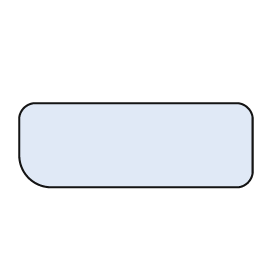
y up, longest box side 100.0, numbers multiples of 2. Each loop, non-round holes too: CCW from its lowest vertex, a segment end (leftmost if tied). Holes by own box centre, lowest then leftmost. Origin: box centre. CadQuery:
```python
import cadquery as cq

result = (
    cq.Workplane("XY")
    .moveTo(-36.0, -18.0)
    .lineTo(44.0, -18.0)
    .threePointArc((48.0, -16.0), (50.0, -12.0))
    .lineTo(50.0, 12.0)
    .threePointArc((48.0, 16.0), (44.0, 18.0))
    .lineTo(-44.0, 18.0)
    .threePointArc((-48.0, 16.0), (-50.0, 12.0))
    .lineTo(-50.0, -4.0)
    .threePointArc((-46.0, -14.0), (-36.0, -18.0))
    .close()
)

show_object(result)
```